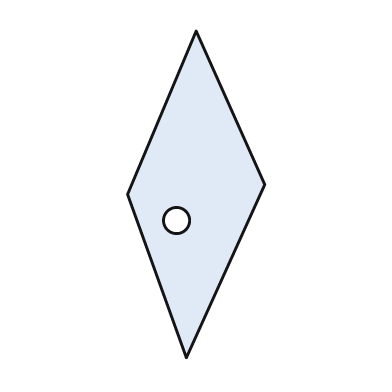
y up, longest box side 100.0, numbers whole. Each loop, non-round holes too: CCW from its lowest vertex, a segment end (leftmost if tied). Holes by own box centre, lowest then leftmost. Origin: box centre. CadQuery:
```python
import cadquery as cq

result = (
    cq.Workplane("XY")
    .moveTo(-3.0, -50.0)
    .lineTo(21.0, 3.0)
    .lineTo(0.0, 50.0)
    .lineTo(-21.0, 0.0)
    .close()
    .moveTo(-6.0, -8.0)
    .circle(4.0)
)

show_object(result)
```